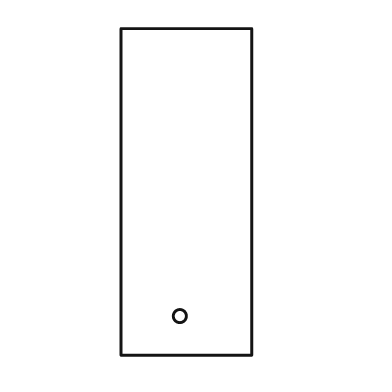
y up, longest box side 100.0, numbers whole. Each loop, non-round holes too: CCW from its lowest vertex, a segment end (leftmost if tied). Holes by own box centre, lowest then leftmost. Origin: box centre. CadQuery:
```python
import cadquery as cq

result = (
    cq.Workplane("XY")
    .moveTo(-20.0, -50.0)
    .lineTo(20.0, -50.0)
    .lineTo(20.0, 50.0)
    .lineTo(-20.0, 50.0)
    .close()
    .moveTo(-2.0, -38.0)
    .circle(2.0)
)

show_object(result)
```